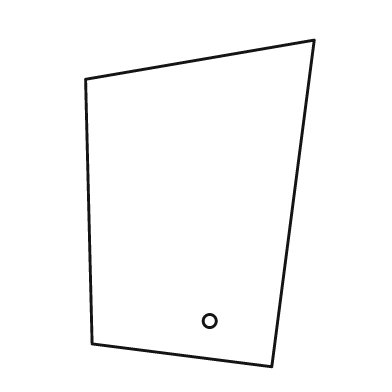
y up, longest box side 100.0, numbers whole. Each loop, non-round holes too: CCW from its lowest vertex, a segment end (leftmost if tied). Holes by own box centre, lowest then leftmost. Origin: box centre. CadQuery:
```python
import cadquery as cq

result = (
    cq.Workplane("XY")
    .moveTo(22.0, -50.0)
    .lineTo(35.0, 50.0)
    .lineTo(-35.0, 38.0)
    .lineTo(-33.0, -43.0)
    .close()
    .moveTo(3.0, -36.0)
    .circle(2.0)
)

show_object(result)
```